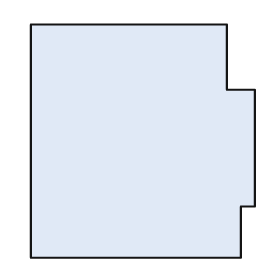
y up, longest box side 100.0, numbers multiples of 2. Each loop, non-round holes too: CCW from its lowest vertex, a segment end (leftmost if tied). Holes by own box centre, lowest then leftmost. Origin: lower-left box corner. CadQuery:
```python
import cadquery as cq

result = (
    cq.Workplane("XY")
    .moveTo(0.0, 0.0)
    .lineTo(90.0, 0.0)
    .lineTo(90.0, 22.0)
    .lineTo(96.0, 22.0)
    .lineTo(96.0, 72.0)
    .lineTo(84.0, 72.0)
    .lineTo(84.0, 100.0)
    .lineTo(0.0, 100.0)
    .close()
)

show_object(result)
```